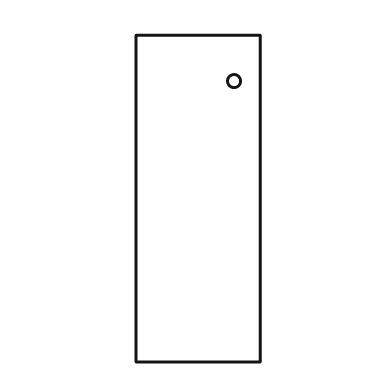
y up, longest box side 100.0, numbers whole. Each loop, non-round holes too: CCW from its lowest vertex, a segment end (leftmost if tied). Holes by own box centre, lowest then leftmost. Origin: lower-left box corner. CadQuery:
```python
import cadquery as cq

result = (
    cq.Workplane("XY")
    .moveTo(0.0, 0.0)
    .lineTo(38.0, 0.0)
    .lineTo(38.0, 100.0)
    .lineTo(0.0, 100.0)
    .close()
    .moveTo(30.0, 86.0)
    .circle(2.0)
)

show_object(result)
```